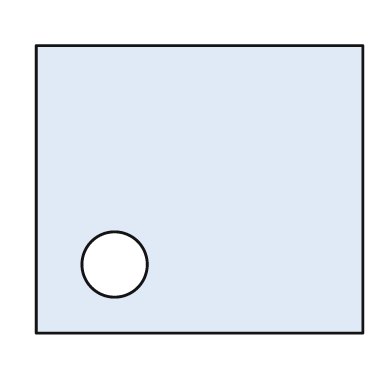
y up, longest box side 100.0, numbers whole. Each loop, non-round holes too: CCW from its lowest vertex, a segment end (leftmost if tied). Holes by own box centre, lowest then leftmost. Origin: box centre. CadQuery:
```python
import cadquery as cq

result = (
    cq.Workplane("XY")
    .moveTo(-50.0, -44.0)
    .lineTo(50.0, -44.0)
    .lineTo(50.0, 44.0)
    .lineTo(-50.0, 44.0)
    .close()
    .moveTo(-26.0, -23.0)
    .circle(10.0)
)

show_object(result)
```